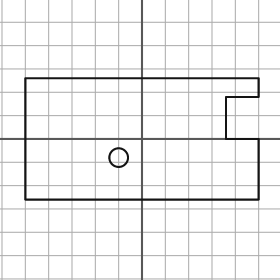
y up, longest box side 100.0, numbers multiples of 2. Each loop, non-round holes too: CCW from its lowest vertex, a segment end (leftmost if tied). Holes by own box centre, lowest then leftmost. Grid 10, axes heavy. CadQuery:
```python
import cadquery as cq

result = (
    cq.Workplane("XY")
    .moveTo(-50.0, -26.0)
    .lineTo(50.0, -26.0)
    .lineTo(50.0, 0.0)
    .lineTo(36.0, 0.0)
    .lineTo(36.0, 18.0)
    .lineTo(50.0, 18.0)
    .lineTo(50.0, 26.0)
    .lineTo(-50.0, 26.0)
    .close()
    .moveTo(-10.0, -8.0)
    .circle(4.0)
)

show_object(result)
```